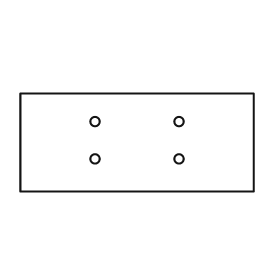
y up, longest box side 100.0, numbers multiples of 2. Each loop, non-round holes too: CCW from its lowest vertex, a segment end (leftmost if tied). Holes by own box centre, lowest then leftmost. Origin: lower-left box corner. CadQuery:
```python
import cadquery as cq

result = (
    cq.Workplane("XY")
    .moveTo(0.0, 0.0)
    .lineTo(100.0, 0.0)
    .lineTo(100.0, 42.0)
    .lineTo(0.0, 42.0)
    .close()
    .moveTo(32.0, 14.0)
    .circle(2.0)
    .moveTo(68.0, 14.0)
    .circle(2.0)
    .moveTo(32.0, 30.0)
    .circle(2.0)
    .moveTo(68.0, 30.0)
    .circle(2.0)
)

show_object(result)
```